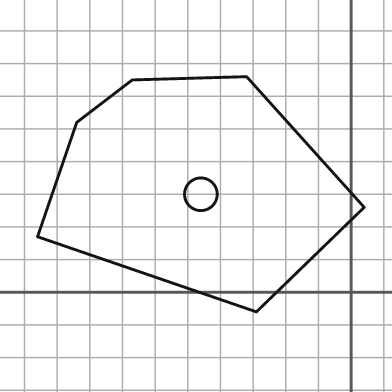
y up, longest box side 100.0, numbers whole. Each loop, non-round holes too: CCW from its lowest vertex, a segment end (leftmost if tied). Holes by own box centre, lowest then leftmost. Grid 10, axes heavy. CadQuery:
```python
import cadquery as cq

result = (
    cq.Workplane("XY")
    .moveTo(-29.0, -6.0)
    .lineTo(4.0, 26.0)
    .lineTo(-32.0, 66.0)
    .lineTo(-67.0, 65.0)
    .lineTo(-84.0, 52.0)
    .lineTo(-96.0, 17.0)
    .close()
    .moveTo(-46.0, 30.0)
    .circle(5.0)
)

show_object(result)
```